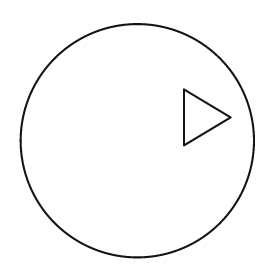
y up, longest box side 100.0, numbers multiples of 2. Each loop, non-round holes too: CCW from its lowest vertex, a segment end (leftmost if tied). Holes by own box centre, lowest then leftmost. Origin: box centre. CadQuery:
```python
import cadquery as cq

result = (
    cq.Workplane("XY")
    .moveTo(0.0, 0.0)
    .circle(50.0)
    .moveTo(20.0, -2.0)
    .lineTo(40.0, 10.0)
    .lineTo(20.0, 22.0)
    .close()
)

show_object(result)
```